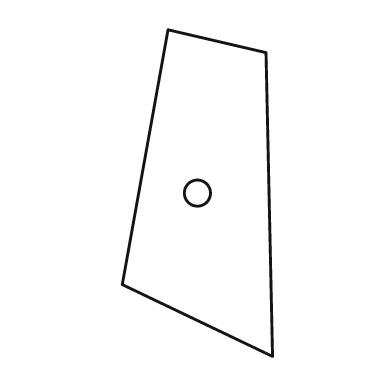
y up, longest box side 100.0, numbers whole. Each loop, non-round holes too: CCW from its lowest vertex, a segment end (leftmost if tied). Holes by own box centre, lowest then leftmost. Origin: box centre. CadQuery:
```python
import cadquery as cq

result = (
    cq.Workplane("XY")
    .moveTo(23.0, -50.0)
    .lineTo(21.0, 43.0)
    .lineTo(-9.0, 50.0)
    .lineTo(-23.0, -28.0)
    .close()
    .moveTo(0.0, 0.0)
    .circle(4.0)
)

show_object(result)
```